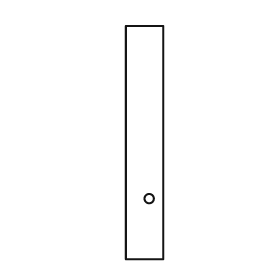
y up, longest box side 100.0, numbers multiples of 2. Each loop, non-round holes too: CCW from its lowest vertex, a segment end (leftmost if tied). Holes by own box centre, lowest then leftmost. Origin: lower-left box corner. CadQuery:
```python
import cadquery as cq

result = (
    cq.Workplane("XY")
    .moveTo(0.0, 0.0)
    .lineTo(16.0, 0.0)
    .lineTo(16.0, 100.0)
    .lineTo(0.0, 100.0)
    .close()
    .moveTo(10.0, 26.0)
    .circle(2.0)
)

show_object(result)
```